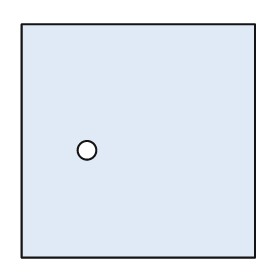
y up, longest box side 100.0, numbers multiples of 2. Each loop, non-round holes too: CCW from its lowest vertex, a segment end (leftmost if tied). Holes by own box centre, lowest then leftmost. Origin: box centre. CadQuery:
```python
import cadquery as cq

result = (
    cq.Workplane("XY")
    .moveTo(-50.0, -50.0)
    .lineTo(50.0, -50.0)
    .lineTo(50.0, 50.0)
    .lineTo(-50.0, 50.0)
    .close()
    .moveTo(-22.0, -4.0)
    .circle(4.0)
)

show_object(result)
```